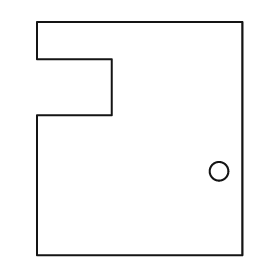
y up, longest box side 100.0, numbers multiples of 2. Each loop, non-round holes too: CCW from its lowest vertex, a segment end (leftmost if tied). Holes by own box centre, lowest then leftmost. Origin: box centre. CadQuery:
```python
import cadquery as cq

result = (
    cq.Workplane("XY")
    .moveTo(-44.0, -50.0)
    .lineTo(44.0, -50.0)
    .lineTo(44.0, 50.0)
    .lineTo(-44.0, 50.0)
    .lineTo(-44.0, 34.0)
    .lineTo(-12.0, 34.0)
    .lineTo(-12.0, 10.0)
    .lineTo(-44.0, 10.0)
    .close()
    .moveTo(34.0, -14.0)
    .circle(4.0)
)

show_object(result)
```